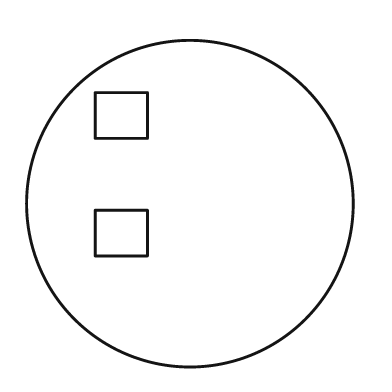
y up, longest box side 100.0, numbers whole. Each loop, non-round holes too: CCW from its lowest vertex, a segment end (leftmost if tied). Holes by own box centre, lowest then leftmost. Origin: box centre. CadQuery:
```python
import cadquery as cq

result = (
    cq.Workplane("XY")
    .moveTo(0.0, 0.0)
    .circle(50.0)
    .moveTo(-29.0, -16.0)
    .lineTo(-13.0, -16.0)
    .lineTo(-13.0, -2.0)
    .lineTo(-29.0, -2.0)
    .close()
    .moveTo(-29.0, 20.0)
    .lineTo(-13.0, 20.0)
    .lineTo(-13.0, 34.0)
    .lineTo(-29.0, 34.0)
    .close()
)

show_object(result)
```